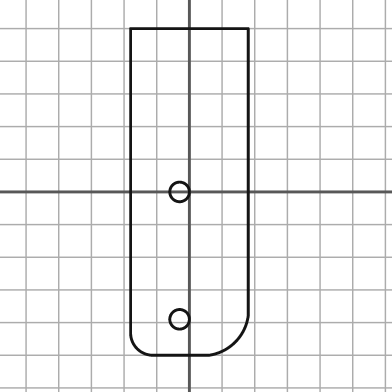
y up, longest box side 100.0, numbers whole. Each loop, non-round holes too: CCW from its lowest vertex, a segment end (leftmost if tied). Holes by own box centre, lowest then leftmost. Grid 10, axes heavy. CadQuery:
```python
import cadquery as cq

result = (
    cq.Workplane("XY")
    .moveTo(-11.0, -50.0)
    .lineTo(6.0, -50.0)
    .threePointArc((14.0, -46.0), (18.0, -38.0))
    .lineTo(18.0, 50.0)
    .lineTo(-18.0, 50.0)
    .lineTo(-18.0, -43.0)
    .threePointArc((-16.0, -48.0), (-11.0, -50.0))
    .close()
    .moveTo(-3.0, -39.0)
    .circle(3.0)
    .moveTo(-3.0, 0.0)
    .circle(3.0)
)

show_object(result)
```